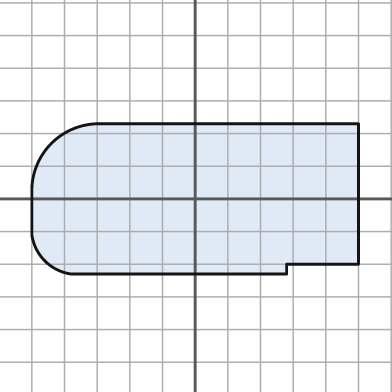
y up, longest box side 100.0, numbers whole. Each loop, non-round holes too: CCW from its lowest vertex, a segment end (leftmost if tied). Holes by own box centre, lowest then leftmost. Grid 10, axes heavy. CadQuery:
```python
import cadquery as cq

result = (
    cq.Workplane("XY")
    .moveTo(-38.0, -23.0)
    .lineTo(28.0, -23.0)
    .lineTo(28.0, -20.0)
    .lineTo(50.0, -20.0)
    .lineTo(50.0, 23.0)
    .lineTo(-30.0, 23.0)
    .threePointArc((-44.0, 17.0), (-50.0, 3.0))
    .lineTo(-50.0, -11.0)
    .threePointArc((-46.0, -19.0), (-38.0, -23.0))
    .close()
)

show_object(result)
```